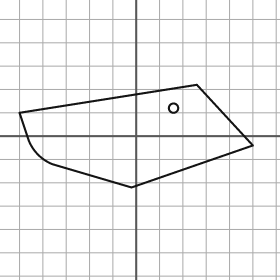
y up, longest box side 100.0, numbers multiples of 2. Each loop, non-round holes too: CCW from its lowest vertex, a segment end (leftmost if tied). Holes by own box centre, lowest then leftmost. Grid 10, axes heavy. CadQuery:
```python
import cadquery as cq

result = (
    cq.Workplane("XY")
    .moveTo(-2.0, -22.0)
    .lineTo(50.0, -4.0)
    .lineTo(26.0, 22.0)
    .lineTo(-50.0, 10.0)
    .lineTo(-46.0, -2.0)
    .threePointArc((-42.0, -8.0), (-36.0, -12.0))
    .close()
    .moveTo(16.0, 12.0)
    .circle(2.0)
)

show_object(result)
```